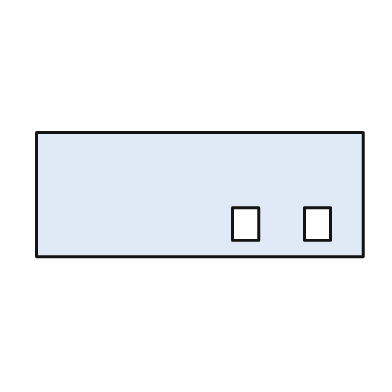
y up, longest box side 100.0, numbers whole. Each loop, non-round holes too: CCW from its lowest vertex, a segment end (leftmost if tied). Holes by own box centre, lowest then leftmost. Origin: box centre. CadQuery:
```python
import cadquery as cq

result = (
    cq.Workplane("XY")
    .moveTo(-50.0, -19.0)
    .lineTo(50.0, -19.0)
    .lineTo(50.0, 19.0)
    .lineTo(-50.0, 19.0)
    .close()
    .moveTo(10.0, -14.0)
    .lineTo(18.0, -14.0)
    .lineTo(18.0, -4.0)
    .lineTo(10.0, -4.0)
    .close()
    .moveTo(32.0, -14.0)
    .lineTo(40.0, -14.0)
    .lineTo(40.0, -4.0)
    .lineTo(32.0, -4.0)
    .close()
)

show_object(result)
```